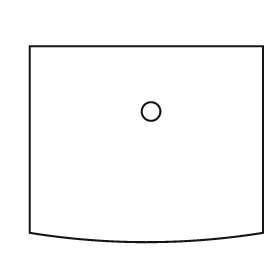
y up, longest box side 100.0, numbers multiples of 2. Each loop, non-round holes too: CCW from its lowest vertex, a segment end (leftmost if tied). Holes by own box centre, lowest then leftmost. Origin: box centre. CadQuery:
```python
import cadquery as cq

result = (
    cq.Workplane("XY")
    .moveTo(-50.0, -38.0)
    .threePointArc((0.0, -42.0), (50.0, -38.0))
    .lineTo(50.0, 42.0)
    .lineTo(-50.0, 42.0)
    .close()
    .moveTo(2.0, 14.0)
    .circle(4.0)
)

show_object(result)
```